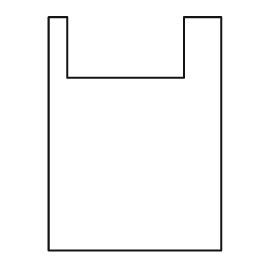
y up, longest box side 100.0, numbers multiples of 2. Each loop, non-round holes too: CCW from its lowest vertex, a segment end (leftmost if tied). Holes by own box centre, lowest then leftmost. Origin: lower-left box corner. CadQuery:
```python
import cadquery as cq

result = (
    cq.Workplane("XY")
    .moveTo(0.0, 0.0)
    .lineTo(74.0, 0.0)
    .lineTo(74.0, 100.0)
    .lineTo(58.0, 100.0)
    .lineTo(58.0, 74.0)
    .lineTo(8.0, 74.0)
    .lineTo(8.0, 100.0)
    .lineTo(0.0, 100.0)
    .close()
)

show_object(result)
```